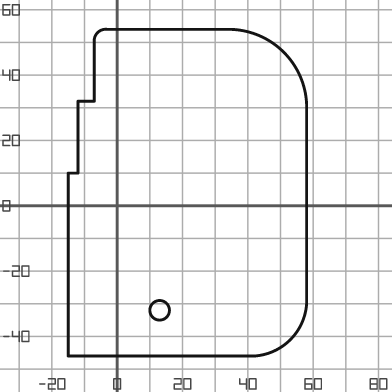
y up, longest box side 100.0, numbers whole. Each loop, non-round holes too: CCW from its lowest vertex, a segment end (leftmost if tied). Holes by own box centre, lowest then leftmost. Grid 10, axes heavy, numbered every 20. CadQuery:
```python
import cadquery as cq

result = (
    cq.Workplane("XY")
    .moveTo(-15.0, -46.0)
    .lineTo(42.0, -46.0)
    .threePointArc((53.0, -41.0), (58.0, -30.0))
    .lineTo(58.0, 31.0)
    .threePointArc((51.0, 47.0), (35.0, 54.0))
    .lineTo(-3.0, 54.0)
    .threePointArc((-6.0, 53.0), (-7.0, 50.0))
    .lineTo(-7.0, 32.0)
    .lineTo(-12.0, 32.0)
    .lineTo(-12.0, 10.0)
    .lineTo(-15.0, 10.0)
    .close()
    .moveTo(13.0, -32.0)
    .circle(3.0)
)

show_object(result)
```